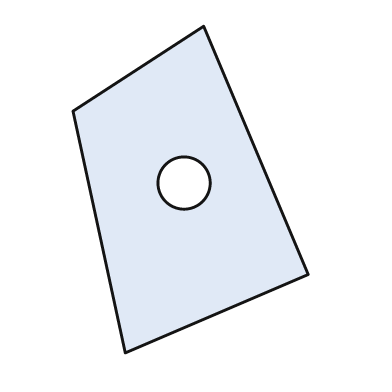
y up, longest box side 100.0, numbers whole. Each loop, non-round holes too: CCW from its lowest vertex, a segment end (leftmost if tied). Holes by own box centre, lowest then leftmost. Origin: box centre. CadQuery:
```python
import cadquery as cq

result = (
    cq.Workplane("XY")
    .moveTo(-20.0, -50.0)
    .lineTo(36.0, -26.0)
    .lineTo(4.0, 50.0)
    .lineTo(-36.0, 24.0)
    .close()
    .moveTo(-2.0, 2.0)
    .circle(8.0)
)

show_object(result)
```